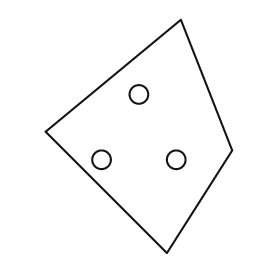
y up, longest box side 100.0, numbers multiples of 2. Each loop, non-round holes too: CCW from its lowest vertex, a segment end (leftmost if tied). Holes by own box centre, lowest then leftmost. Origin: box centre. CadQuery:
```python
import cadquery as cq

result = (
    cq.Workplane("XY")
    .moveTo(12.0, -50.0)
    .lineTo(40.0, -6.0)
    .lineTo(18.0, 50.0)
    .lineTo(-40.0, 2.0)
    .close()
    .moveTo(-16.0, -10.0)
    .circle(4.0)
    .moveTo(16.0, -10.0)
    .circle(4.0)
    .moveTo(0.0, 18.0)
    .circle(4.0)
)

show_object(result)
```